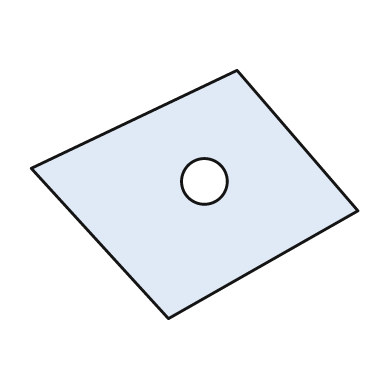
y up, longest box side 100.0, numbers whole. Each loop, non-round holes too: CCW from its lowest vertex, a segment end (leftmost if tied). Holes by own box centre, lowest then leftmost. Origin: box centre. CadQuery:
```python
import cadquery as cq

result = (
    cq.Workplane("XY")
    .moveTo(-8.0, -38.0)
    .lineTo(50.0, -5.0)
    .lineTo(13.0, 38.0)
    .lineTo(-50.0, 8.0)
    .close()
    .moveTo(3.0, 4.0)
    .circle(7.0)
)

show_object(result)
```